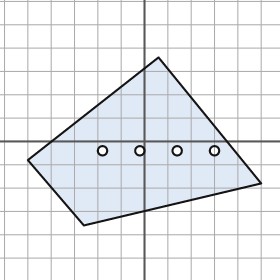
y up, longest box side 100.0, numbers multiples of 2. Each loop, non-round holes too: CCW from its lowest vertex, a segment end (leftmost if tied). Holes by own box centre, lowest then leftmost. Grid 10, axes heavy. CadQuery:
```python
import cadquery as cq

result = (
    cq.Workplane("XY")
    .moveTo(-26.0, -36.0)
    .lineTo(50.0, -18.0)
    .lineTo(6.0, 36.0)
    .lineTo(-50.0, -8.0)
    .close()
    .moveTo(-18.0, -4.0)
    .circle(2.0)
    .moveTo(-2.0, -4.0)
    .circle(2.0)
    .moveTo(14.0, -4.0)
    .circle(2.0)
    .moveTo(30.0, -4.0)
    .circle(2.0)
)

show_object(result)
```